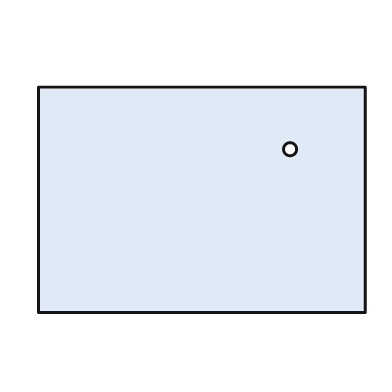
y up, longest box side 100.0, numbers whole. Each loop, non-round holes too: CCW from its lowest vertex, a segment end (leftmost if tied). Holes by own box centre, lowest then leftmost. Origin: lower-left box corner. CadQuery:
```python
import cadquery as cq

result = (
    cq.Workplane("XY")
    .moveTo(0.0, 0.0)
    .lineTo(100.0, 0.0)
    .lineTo(100.0, 69.0)
    .lineTo(0.0, 69.0)
    .close()
    .moveTo(77.0, 50.0)
    .circle(2.0)
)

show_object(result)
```